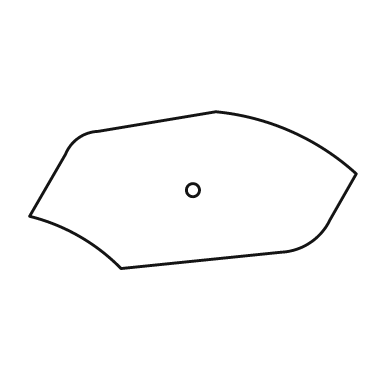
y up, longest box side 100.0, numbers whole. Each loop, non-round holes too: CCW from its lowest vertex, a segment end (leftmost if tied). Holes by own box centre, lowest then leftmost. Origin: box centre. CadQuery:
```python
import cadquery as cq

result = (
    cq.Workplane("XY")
    .moveTo(-22.0, -24.0)
    .lineTo(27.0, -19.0)
    .threePointArc((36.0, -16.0), (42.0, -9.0))
    .lineTo(50.0, 5.0)
    .threePointArc((30.0, 18.0), (7.0, 24.0))
    .lineTo(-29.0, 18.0)
    .threePointArc((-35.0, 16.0), (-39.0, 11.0))
    .lineTo(-50.0, -8.0)
    .threePointArc((-35.0, -14.0), (-22.0, -24.0))
    .close()
    .moveTo(0.0, 0.0)
    .circle(2.0)
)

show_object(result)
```